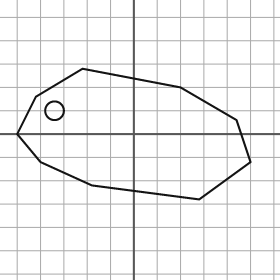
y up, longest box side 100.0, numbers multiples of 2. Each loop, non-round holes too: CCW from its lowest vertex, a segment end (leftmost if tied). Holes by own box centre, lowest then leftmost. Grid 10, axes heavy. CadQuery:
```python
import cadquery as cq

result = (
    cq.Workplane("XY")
    .moveTo(28.0, -28.0)
    .lineTo(50.0, -12.0)
    .lineTo(44.0, 6.0)
    .lineTo(20.0, 20.0)
    .lineTo(-22.0, 28.0)
    .lineTo(-42.0, 16.0)
    .lineTo(-50.0, 0.0)
    .lineTo(-40.0, -12.0)
    .lineTo(-18.0, -22.0)
    .close()
    .moveTo(-34.0, 10.0)
    .circle(4.0)
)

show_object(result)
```